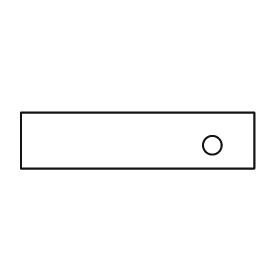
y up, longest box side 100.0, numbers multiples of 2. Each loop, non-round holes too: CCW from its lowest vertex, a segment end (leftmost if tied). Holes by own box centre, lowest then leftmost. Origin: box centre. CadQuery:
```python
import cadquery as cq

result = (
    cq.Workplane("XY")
    .moveTo(-50.0, -12.0)
    .lineTo(50.0, -12.0)
    .lineTo(50.0, 12.0)
    .lineTo(-50.0, 12.0)
    .close()
    .moveTo(32.0, -2.0)
    .circle(4.0)
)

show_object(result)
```